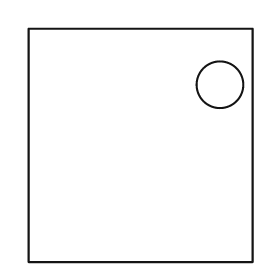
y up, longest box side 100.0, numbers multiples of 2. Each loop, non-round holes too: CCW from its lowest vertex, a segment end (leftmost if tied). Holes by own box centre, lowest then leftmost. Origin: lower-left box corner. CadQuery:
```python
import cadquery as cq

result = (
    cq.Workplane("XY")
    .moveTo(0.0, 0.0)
    .lineTo(96.0, 0.0)
    .lineTo(96.0, 100.0)
    .lineTo(0.0, 100.0)
    .close()
    .moveTo(82.0, 76.0)
    .circle(10.0)
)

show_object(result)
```